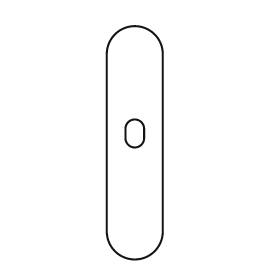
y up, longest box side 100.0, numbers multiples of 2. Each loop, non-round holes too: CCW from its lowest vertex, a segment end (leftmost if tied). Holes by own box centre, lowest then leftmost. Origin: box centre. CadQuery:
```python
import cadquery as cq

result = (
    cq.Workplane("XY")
    .moveTo(-12.0, -38.0)
    .threePointArc((0.0, -50.0), (12.0, -38.0))
    .lineTo(12.0, 38.0)
    .threePointArc((0.0, 50.0), (-12.0, 38.0))
    .close()
    .moveTo(-4.0, 2.0)
    .threePointArc((0.0, -2.0), (4.0, 2.0))
    .lineTo(4.0, 6.0)
    .threePointArc((0.0, 10.0), (-4.0, 6.0))
    .close()
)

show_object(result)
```